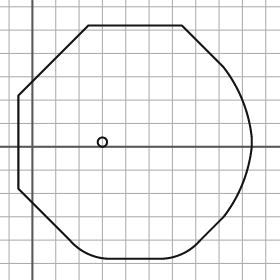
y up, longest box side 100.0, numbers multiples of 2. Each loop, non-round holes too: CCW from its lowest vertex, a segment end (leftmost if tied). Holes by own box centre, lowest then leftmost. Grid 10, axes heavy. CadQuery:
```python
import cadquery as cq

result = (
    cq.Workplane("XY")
    .moveTo(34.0, -48.0)
    .lineTo(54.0, -48.0)
    .threePointArc((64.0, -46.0), (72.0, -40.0))
    .lineTo(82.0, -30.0)
    .threePointArc((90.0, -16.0), (94.0, 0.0))
    .lineTo(94.0, 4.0)
    .threePointArc((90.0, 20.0), (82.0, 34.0))
    .lineTo(64.0, 52.0)
    .lineTo(24.0, 52.0)
    .lineTo(-6.0, 22.0)
    .lineTo(-6.0, -18.0)
    .lineTo(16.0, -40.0)
    .threePointArc((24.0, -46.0), (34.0, -48.0))
    .close()
    .moveTo(30.0, 2.0)
    .circle(2.0)
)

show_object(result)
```